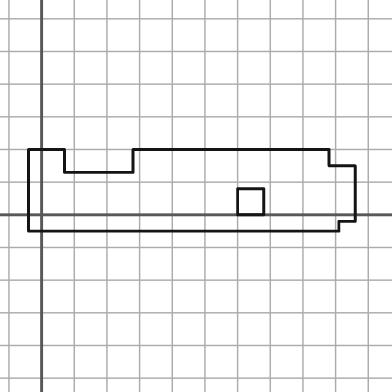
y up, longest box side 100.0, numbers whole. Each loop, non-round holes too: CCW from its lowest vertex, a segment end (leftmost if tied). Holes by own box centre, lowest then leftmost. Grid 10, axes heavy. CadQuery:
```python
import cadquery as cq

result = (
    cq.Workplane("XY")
    .moveTo(-4.0, -5.0)
    .lineTo(91.0, -5.0)
    .lineTo(91.0, -2.0)
    .lineTo(96.0, -2.0)
    .lineTo(96.0, 15.0)
    .lineTo(88.0, 15.0)
    .lineTo(88.0, 20.0)
    .lineTo(28.0, 20.0)
    .lineTo(28.0, 13.0)
    .lineTo(7.0, 13.0)
    .lineTo(7.0, 20.0)
    .lineTo(-4.0, 20.0)
    .close()
    .moveTo(60.0, 0.0)
    .lineTo(68.0, 0.0)
    .lineTo(68.0, 8.0)
    .lineTo(60.0, 8.0)
    .close()
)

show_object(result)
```